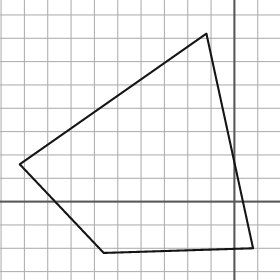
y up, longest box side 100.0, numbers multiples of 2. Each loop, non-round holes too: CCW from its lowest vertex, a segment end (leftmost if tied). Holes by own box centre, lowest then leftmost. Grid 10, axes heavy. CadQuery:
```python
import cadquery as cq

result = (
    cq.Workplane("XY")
    .moveTo(-56.0, -22.0)
    .lineTo(8.0, -20.0)
    .lineTo(-12.0, 72.0)
    .lineTo(-92.0, 16.0)
    .close()
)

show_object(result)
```